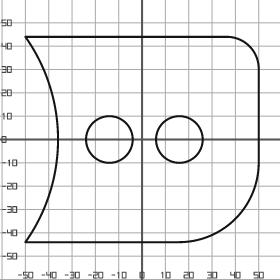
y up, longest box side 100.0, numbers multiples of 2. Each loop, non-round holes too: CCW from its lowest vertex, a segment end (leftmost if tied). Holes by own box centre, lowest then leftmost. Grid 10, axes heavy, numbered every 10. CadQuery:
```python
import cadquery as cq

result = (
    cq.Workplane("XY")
    .moveTo(-50.0, -44.0)
    .lineTo(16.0, -44.0)
    .threePointArc((40.0, -34.0), (50.0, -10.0))
    .lineTo(50.0, 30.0)
    .threePointArc((46.0, 40.0), (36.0, 44.0))
    .lineTo(-50.0, 44.0)
    .threePointArc((-36.0, 0.0), (-50.0, -44.0))
    .close()
    .moveTo(-14.0, 0.0)
    .circle(10.0)
    .moveTo(16.0, 0.0)
    .circle(10.0)
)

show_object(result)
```